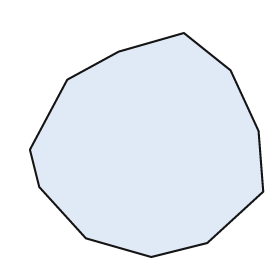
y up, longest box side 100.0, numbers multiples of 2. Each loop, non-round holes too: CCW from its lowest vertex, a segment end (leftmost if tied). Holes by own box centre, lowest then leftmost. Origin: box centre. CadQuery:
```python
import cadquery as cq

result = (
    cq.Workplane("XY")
    .moveTo(2.0, -48.0)
    .lineTo(26.0, -42.0)
    .lineTo(50.0, -20.0)
    .lineTo(48.0, 6.0)
    .lineTo(36.0, 32.0)
    .lineTo(16.0, 48.0)
    .lineTo(-12.0, 40.0)
    .lineTo(-34.0, 28.0)
    .lineTo(-50.0, -2.0)
    .lineTo(-46.0, -18.0)
    .lineTo(-26.0, -40.0)
    .close()
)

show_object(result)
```